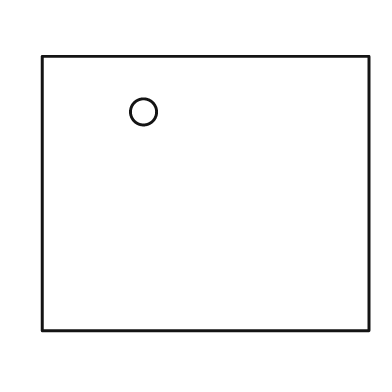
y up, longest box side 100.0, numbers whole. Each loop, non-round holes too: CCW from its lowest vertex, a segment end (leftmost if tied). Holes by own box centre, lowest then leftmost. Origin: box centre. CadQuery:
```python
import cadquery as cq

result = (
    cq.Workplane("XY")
    .moveTo(-50.0, -42.0)
    .lineTo(50.0, -42.0)
    .lineTo(50.0, 42.0)
    .lineTo(-50.0, 42.0)
    .close()
    .moveTo(-19.0, 25.0)
    .circle(4.0)
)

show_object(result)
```